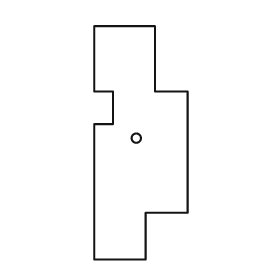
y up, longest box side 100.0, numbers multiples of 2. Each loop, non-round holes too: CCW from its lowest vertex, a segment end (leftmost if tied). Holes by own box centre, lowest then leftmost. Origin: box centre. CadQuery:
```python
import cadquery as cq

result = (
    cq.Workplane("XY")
    .moveTo(-20.0, -50.0)
    .lineTo(2.0, -50.0)
    .lineTo(2.0, -30.0)
    .lineTo(20.0, -30.0)
    .lineTo(20.0, 22.0)
    .lineTo(6.0, 22.0)
    .lineTo(6.0, 50.0)
    .lineTo(-20.0, 50.0)
    .lineTo(-20.0, 22.0)
    .lineTo(-12.0, 22.0)
    .lineTo(-12.0, 8.0)
    .lineTo(-20.0, 8.0)
    .close()
    .moveTo(-2.0, 2.0)
    .circle(2.0)
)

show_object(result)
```